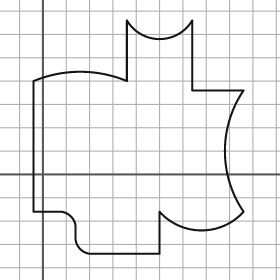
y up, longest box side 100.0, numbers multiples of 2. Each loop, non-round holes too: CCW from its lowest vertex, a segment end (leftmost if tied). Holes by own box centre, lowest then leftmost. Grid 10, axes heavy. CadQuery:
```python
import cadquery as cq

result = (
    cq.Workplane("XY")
    .moveTo(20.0, -34.0)
    .lineTo(50.0, -34.0)
    .lineTo(50.0, -16.0)
    .threePointArc((68.0, -24.0), (86.0, -16.0))
    .threePointArc((78.0, 10.0), (86.0, 36.0))
    .lineTo(64.0, 36.0)
    .lineTo(64.0, 66.0)
    .threePointArc((50.0, 58.0), (36.0, 66.0))
    .lineTo(36.0, 40.0)
    .threePointArc((16.0, 44.0), (-4.0, 40.0))
    .lineTo(-4.0, -16.0)
    .lineTo(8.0, -16.0)
    .threePointArc((12.0, -18.0), (14.0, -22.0))
    .lineTo(14.0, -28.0)
    .threePointArc((16.0, -32.0), (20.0, -34.0))
    .close()
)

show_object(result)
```